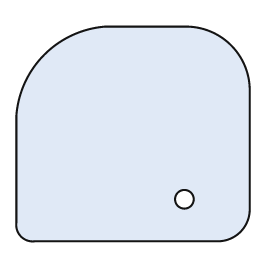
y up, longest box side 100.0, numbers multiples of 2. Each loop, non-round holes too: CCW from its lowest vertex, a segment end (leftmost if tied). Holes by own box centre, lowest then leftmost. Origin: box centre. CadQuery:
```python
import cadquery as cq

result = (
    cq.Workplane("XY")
    .moveTo(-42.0, -46.0)
    .lineTo(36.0, -46.0)
    .threePointArc((46.0, -42.0), (50.0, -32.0))
    .lineTo(50.0, 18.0)
    .threePointArc((42.0, 38.0), (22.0, 46.0))
    .lineTo(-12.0, 46.0)
    .threePointArc((-38.0, 34.0), (-50.0, 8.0))
    .lineTo(-50.0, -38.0)
    .threePointArc((-48.0, -44.0), (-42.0, -46.0))
    .close()
    .moveTo(22.0, -28.0)
    .circle(4.0)
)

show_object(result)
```